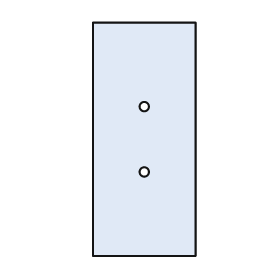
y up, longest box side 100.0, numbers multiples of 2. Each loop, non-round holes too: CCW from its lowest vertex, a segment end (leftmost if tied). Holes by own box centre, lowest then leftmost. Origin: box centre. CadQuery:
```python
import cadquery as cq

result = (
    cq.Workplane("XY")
    .moveTo(-22.0, -50.0)
    .lineTo(22.0, -50.0)
    .lineTo(22.0, 50.0)
    .lineTo(-22.0, 50.0)
    .close()
    .moveTo(0.0, -14.0)
    .circle(2.0)
    .moveTo(0.0, 14.0)
    .circle(2.0)
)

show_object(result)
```